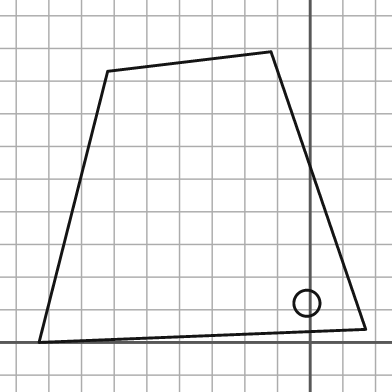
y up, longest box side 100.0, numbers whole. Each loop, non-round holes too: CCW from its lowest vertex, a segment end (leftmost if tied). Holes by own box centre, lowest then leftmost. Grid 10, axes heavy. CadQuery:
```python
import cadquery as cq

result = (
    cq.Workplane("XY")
    .moveTo(-83.0, 0.0)
    .lineTo(17.0, 4.0)
    .lineTo(-12.0, 89.0)
    .lineTo(-62.0, 83.0)
    .close()
    .moveTo(-1.0, 12.0)
    .circle(4.0)
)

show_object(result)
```